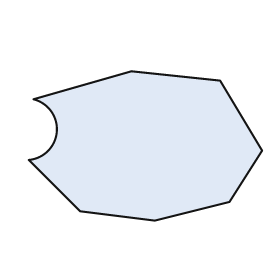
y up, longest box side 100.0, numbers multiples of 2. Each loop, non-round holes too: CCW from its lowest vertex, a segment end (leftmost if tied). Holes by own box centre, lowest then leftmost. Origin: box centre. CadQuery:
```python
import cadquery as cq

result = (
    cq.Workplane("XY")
    .moveTo(4.0, -32.0)
    .lineTo(36.0, -24.0)
    .lineTo(50.0, -2.0)
    .lineTo(32.0, 28.0)
    .lineTo(-6.0, 32.0)
    .lineTo(-48.0, 20.0)
    .threePointArc((-38.0, 6.0), (-50.0, -6.0))
    .lineTo(-28.0, -28.0)
    .close()
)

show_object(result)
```